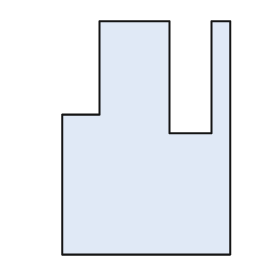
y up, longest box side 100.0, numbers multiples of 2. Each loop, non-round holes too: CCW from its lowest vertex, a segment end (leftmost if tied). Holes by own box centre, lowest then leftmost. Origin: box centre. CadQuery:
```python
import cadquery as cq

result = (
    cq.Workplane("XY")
    .moveTo(-36.0, -50.0)
    .lineTo(36.0, -50.0)
    .lineTo(36.0, 50.0)
    .lineTo(28.0, 50.0)
    .lineTo(28.0, 2.0)
    .lineTo(10.0, 2.0)
    .lineTo(10.0, 50.0)
    .lineTo(-20.0, 50.0)
    .lineTo(-20.0, 10.0)
    .lineTo(-36.0, 10.0)
    .close()
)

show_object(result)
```